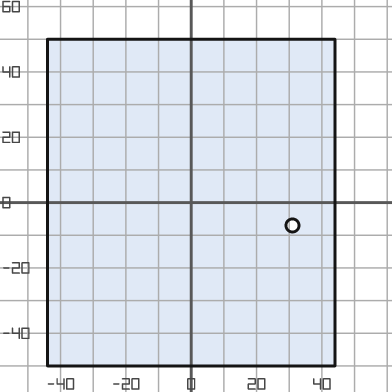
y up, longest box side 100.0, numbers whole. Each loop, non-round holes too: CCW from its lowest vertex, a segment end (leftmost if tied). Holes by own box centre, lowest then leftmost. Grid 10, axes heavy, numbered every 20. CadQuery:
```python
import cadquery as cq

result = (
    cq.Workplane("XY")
    .moveTo(-44.0, -50.0)
    .lineTo(44.0, -50.0)
    .lineTo(44.0, 50.0)
    .lineTo(-44.0, 50.0)
    .close()
    .moveTo(31.0, -7.0)
    .circle(2.0)
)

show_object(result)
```